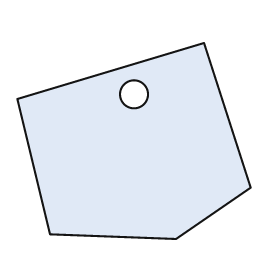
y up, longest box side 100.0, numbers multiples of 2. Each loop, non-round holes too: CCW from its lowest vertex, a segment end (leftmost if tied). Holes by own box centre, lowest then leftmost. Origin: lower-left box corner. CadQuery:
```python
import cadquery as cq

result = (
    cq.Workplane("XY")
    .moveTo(68.0, 0.0)
    .lineTo(100.0, 22.0)
    .lineTo(80.0, 84.0)
    .lineTo(0.0, 60.0)
    .lineTo(14.0, 2.0)
    .close()
    .moveTo(50.0, 62.0)
    .circle(6.0)
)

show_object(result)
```